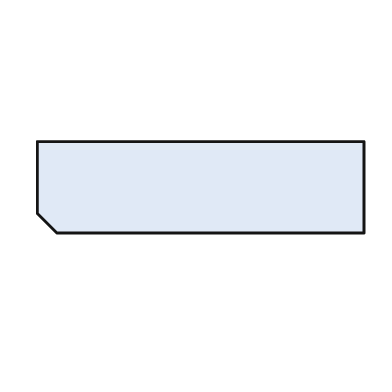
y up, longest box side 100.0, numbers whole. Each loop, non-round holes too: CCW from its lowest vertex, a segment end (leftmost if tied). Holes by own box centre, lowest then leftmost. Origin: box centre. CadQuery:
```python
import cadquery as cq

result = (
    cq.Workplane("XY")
    .moveTo(-44.0, -14.0)
    .lineTo(50.0, -14.0)
    .lineTo(50.0, 14.0)
    .lineTo(-50.0, 14.0)
    .lineTo(-50.0, -8.0)
    .close()
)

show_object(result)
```